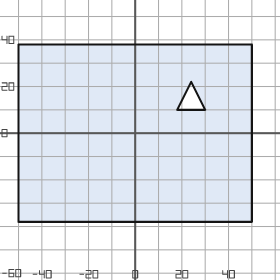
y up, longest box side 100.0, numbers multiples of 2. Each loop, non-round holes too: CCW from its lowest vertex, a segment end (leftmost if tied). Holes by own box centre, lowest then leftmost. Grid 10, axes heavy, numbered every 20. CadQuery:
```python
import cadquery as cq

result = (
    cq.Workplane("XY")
    .moveTo(-50.0, -38.0)
    .lineTo(50.0, -38.0)
    .lineTo(50.0, 38.0)
    .lineTo(-50.0, 38.0)
    .close()
    .moveTo(18.0, 10.0)
    .lineTo(30.0, 10.0)
    .lineTo(24.0, 22.0)
    .close()
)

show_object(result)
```